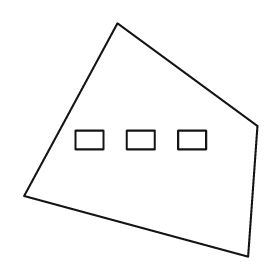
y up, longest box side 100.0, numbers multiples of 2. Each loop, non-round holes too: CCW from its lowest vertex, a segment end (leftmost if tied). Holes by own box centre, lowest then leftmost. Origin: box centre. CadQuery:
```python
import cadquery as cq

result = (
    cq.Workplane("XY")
    .moveTo(46.0, -50.0)
    .lineTo(50.0, 6.0)
    .lineTo(-10.0, 50.0)
    .lineTo(-50.0, -24.0)
    .close()
    .moveTo(-28.0, -4.0)
    .lineTo(-16.0, -4.0)
    .lineTo(-16.0, 4.0)
    .lineTo(-28.0, 4.0)
    .close()
    .moveTo(-6.0, -4.0)
    .lineTo(6.0, -4.0)
    .lineTo(6.0, 4.0)
    .lineTo(-6.0, 4.0)
    .close()
    .moveTo(16.0, -4.0)
    .lineTo(28.0, -4.0)
    .lineTo(28.0, 4.0)
    .lineTo(16.0, 4.0)
    .close()
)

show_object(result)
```